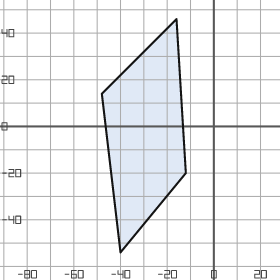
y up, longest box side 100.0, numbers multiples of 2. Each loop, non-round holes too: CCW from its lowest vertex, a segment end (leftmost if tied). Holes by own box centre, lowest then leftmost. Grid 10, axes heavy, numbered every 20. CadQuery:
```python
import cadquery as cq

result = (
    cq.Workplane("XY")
    .moveTo(-40.0, -54.0)
    .lineTo(-12.0, -20.0)
    .lineTo(-16.0, 46.0)
    .lineTo(-48.0, 14.0)
    .close()
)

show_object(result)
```